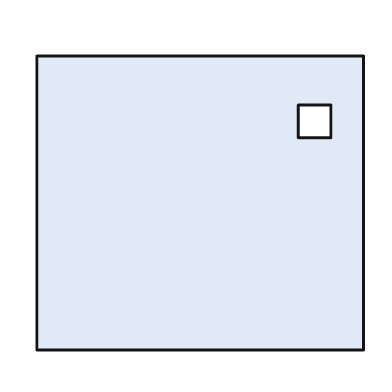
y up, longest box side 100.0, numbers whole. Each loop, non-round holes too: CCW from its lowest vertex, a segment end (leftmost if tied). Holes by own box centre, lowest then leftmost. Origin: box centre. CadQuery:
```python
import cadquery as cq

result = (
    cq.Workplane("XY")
    .moveTo(-50.0, -45.0)
    .lineTo(50.0, -45.0)
    .lineTo(50.0, 45.0)
    .lineTo(-50.0, 45.0)
    .close()
    .moveTo(30.0, 20.0)
    .lineTo(40.0, 20.0)
    .lineTo(40.0, 30.0)
    .lineTo(30.0, 30.0)
    .close()
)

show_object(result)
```